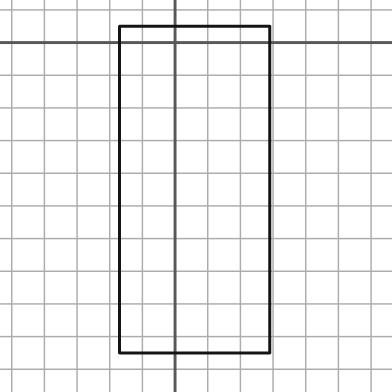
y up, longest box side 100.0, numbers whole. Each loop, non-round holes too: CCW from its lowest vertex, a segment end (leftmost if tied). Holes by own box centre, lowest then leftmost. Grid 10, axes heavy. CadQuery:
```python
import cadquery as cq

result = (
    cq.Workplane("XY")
    .moveTo(-17.0, -95.0)
    .lineTo(29.0, -95.0)
    .lineTo(29.0, 5.0)
    .lineTo(-17.0, 5.0)
    .close()
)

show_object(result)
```